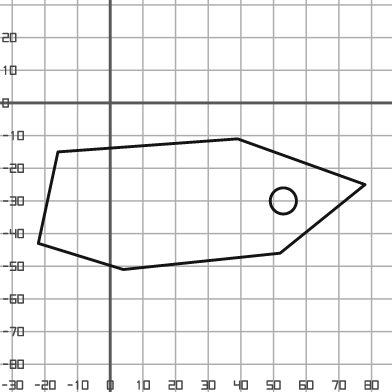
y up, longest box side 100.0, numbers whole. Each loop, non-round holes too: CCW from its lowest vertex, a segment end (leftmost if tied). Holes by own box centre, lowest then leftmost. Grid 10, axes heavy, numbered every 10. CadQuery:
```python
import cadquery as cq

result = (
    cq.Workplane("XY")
    .moveTo(4.0, -51.0)
    .lineTo(52.0, -46.0)
    .lineTo(78.0, -25.0)
    .lineTo(39.0, -11.0)
    .lineTo(-16.0, -15.0)
    .lineTo(-22.0, -43.0)
    .close()
    .moveTo(53.0, -30.0)
    .circle(4.0)
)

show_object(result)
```